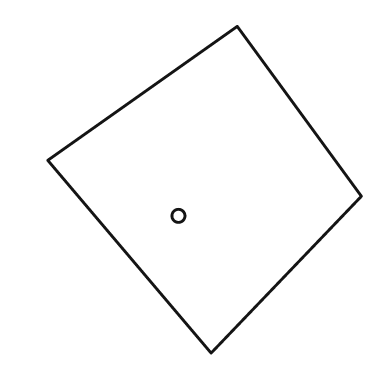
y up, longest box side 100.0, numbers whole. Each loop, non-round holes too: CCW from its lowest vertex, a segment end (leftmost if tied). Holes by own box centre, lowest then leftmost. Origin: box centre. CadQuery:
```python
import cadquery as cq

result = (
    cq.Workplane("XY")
    .moveTo(2.0, -50.0)
    .lineTo(48.0, -2.0)
    .lineTo(10.0, 50.0)
    .lineTo(-48.0, 9.0)
    .close()
    .moveTo(-8.0, -8.0)
    .circle(2.0)
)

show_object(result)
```